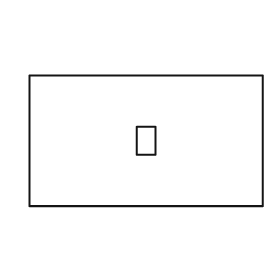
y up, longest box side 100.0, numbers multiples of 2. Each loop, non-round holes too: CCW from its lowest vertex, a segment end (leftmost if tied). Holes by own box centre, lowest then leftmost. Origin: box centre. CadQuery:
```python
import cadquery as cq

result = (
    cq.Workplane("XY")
    .moveTo(-50.0, -28.0)
    .lineTo(50.0, -28.0)
    .lineTo(50.0, 28.0)
    .lineTo(-50.0, 28.0)
    .close()
    .moveTo(-4.0, -6.0)
    .lineTo(4.0, -6.0)
    .lineTo(4.0, 6.0)
    .lineTo(-4.0, 6.0)
    .close()
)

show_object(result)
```